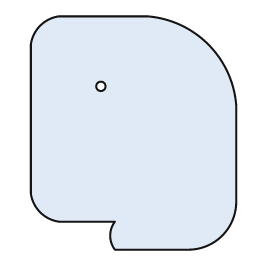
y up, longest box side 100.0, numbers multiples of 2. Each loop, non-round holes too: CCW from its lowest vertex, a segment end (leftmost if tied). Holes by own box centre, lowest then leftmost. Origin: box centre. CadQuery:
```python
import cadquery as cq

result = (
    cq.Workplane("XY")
    .moveTo(-8.0, -50.0)
    .lineTo(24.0, -50.0)
    .threePointArc((38.0, -44.0), (44.0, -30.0))
    .lineTo(44.0, 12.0)
    .threePointArc((32.0, 38.0), (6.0, 50.0))
    .lineTo(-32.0, 50.0)
    .threePointArc((-40.0, 46.0), (-44.0, 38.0))
    .lineTo(-44.0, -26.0)
    .threePointArc((-40.0, -34.0), (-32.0, -38.0))
    .lineTo(-8.0, -38.0)
    .threePointArc((-10.0, -44.0), (-8.0, -50.0))
    .close()
    .moveTo(-14.0, 20.0)
    .circle(2.0)
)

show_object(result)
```